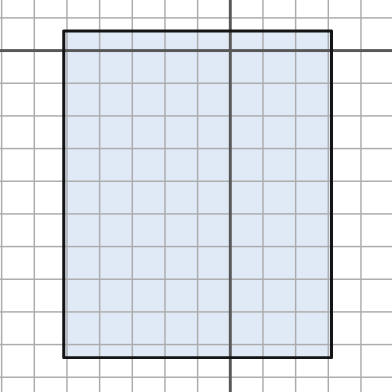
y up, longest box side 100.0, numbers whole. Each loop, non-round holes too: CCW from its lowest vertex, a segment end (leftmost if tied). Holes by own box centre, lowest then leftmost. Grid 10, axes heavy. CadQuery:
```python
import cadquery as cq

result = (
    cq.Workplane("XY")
    .moveTo(-51.0, -94.0)
    .lineTo(31.0, -94.0)
    .lineTo(31.0, 6.0)
    .lineTo(-51.0, 6.0)
    .close()
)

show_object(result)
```